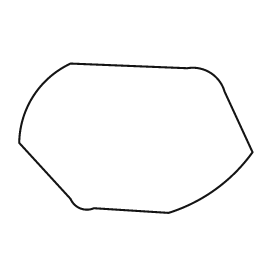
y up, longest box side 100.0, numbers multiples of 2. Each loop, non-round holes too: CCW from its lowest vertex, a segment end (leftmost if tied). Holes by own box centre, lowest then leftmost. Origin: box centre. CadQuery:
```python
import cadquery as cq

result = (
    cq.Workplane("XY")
    .moveTo(14.0, -32.0)
    .threePointArc((34.0, -22.0), (50.0, -6.0))
    .lineTo(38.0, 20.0)
    .threePointArc((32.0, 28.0), (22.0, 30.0))
    .lineTo(-28.0, 32.0)
    .threePointArc((-44.0, 18.0), (-50.0, -2.0))
    .lineTo(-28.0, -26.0)
    .threePointArc((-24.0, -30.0), (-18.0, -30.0))
    .close()
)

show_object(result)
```